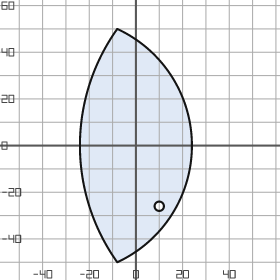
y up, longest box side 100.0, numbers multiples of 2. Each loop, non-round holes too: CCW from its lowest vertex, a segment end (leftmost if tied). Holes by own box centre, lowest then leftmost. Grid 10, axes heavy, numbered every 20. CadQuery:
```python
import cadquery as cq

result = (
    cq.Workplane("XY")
    .moveTo(-8.0, -50.0)
    .threePointArc((24.0, 0.0), (-8.0, 50.0))
    .threePointArc((-24.0, 0.0), (-8.0, -50.0))
    .close()
    .moveTo(10.0, -26.0)
    .circle(2.0)
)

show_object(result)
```